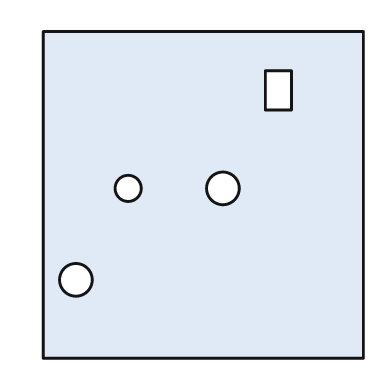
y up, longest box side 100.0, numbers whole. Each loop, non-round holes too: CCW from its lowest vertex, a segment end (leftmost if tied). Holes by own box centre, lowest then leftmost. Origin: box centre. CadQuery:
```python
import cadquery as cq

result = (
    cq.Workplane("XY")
    .moveTo(-49.0, -50.0)
    .lineTo(49.0, -50.0)
    .lineTo(49.0, 50.0)
    .lineTo(-49.0, 50.0)
    .close()
    .moveTo(-39.0, -26.0)
    .circle(5.0)
    .moveTo(-23.0, 2.0)
    .circle(4.0)
    .moveTo(6.0, 2.0)
    .circle(5.0)
    .moveTo(19.0, 26.0)
    .lineTo(27.0, 26.0)
    .lineTo(27.0, 38.0)
    .lineTo(19.0, 38.0)
    .close()
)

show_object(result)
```